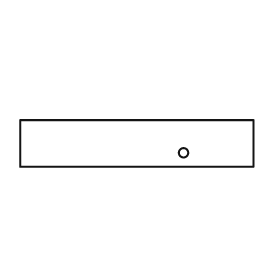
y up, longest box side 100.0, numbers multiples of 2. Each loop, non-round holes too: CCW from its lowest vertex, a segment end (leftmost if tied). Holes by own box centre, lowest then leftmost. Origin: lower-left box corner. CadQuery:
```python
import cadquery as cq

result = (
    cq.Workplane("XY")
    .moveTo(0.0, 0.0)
    .lineTo(100.0, 0.0)
    .lineTo(100.0, 20.0)
    .lineTo(0.0, 20.0)
    .close()
    .moveTo(70.0, 6.0)
    .circle(2.0)
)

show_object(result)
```